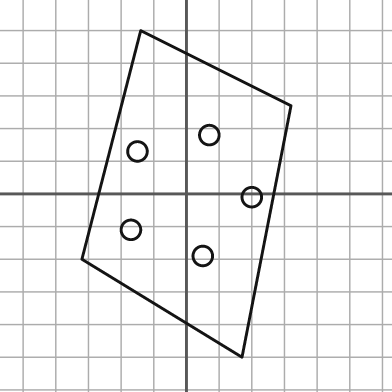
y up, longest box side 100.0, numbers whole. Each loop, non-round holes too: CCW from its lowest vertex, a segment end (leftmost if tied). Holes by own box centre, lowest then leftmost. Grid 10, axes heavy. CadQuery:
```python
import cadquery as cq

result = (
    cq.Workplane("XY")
    .moveTo(17.0, -50.0)
    .lineTo(32.0, 27.0)
    .lineTo(-14.0, 50.0)
    .lineTo(-32.0, -20.0)
    .close()
    .moveTo(5.0, -19.0)
    .circle(3.0)
    .moveTo(-17.0, -11.0)
    .circle(3.0)
    .moveTo(20.0, -1.0)
    .circle(3.0)
    .moveTo(-15.0, 13.0)
    .circle(3.0)
    .moveTo(7.0, 18.0)
    .circle(3.0)
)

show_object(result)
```